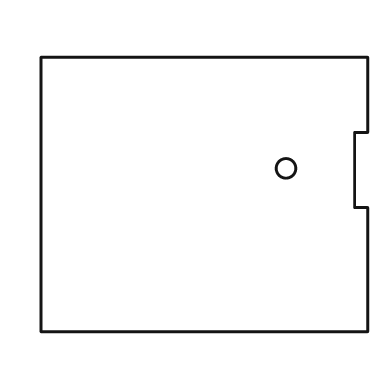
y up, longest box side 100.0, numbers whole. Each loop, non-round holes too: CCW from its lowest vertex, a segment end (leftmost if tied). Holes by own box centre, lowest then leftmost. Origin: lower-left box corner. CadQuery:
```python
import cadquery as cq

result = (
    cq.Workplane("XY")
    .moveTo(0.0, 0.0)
    .lineTo(100.0, 0.0)
    .lineTo(100.0, 38.0)
    .lineTo(96.0, 38.0)
    .lineTo(96.0, 61.0)
    .lineTo(100.0, 61.0)
    .lineTo(100.0, 84.0)
    .lineTo(0.0, 84.0)
    .close()
    .moveTo(75.0, 50.0)
    .circle(3.0)
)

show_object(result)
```